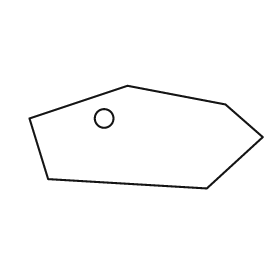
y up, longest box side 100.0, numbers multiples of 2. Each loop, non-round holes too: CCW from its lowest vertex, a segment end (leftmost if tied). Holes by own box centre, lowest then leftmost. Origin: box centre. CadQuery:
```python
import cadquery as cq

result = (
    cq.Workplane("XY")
    .moveTo(26.0, -22.0)
    .lineTo(50.0, 0.0)
    .lineTo(34.0, 14.0)
    .lineTo(-8.0, 22.0)
    .lineTo(-50.0, 8.0)
    .lineTo(-42.0, -18.0)
    .close()
    .moveTo(-18.0, 8.0)
    .circle(4.0)
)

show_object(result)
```